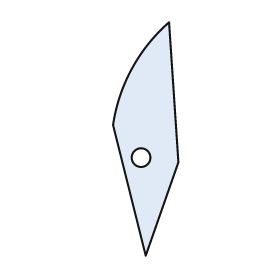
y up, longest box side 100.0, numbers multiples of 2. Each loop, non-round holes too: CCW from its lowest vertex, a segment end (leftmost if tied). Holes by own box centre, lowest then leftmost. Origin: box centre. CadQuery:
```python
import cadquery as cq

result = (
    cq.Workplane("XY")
    .moveTo(0.0, -50.0)
    .lineTo(14.0, -10.0)
    .lineTo(10.0, 50.0)
    .threePointArc((-6.0, 30.0), (-14.0, 6.0))
    .close()
    .moveTo(-2.0, -8.0)
    .circle(4.0)
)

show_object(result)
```